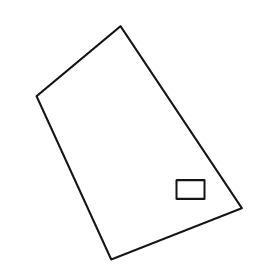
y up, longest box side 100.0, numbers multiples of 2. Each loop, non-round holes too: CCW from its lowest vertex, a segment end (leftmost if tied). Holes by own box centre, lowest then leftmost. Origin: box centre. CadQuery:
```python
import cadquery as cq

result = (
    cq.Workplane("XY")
    .moveTo(-12.0, -50.0)
    .lineTo(44.0, -28.0)
    .lineTo(-8.0, 50.0)
    .lineTo(-44.0, 20.0)
    .close()
    .moveTo(16.0, -24.0)
    .lineTo(28.0, -24.0)
    .lineTo(28.0, -16.0)
    .lineTo(16.0, -16.0)
    .close()
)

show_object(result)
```